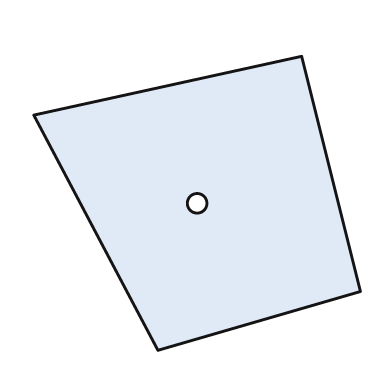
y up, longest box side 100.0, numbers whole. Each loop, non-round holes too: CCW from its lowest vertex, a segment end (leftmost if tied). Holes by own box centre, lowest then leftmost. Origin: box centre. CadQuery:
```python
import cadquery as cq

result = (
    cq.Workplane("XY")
    .moveTo(-12.0, -45.0)
    .lineTo(50.0, -27.0)
    .lineTo(32.0, 45.0)
    .lineTo(-50.0, 27.0)
    .close()
    .moveTo(0.0, 0.0)
    .circle(3.0)
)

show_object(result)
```